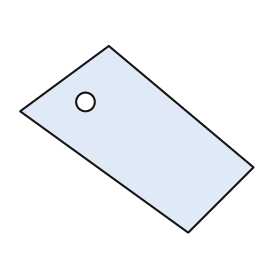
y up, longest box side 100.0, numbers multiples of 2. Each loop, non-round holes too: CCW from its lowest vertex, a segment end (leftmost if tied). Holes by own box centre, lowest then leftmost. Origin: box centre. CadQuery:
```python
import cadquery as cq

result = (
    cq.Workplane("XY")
    .moveTo(22.0, -40.0)
    .lineTo(50.0, -12.0)
    .lineTo(-12.0, 40.0)
    .lineTo(-50.0, 12.0)
    .close()
    .moveTo(-22.0, 16.0)
    .circle(4.0)
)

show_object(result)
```